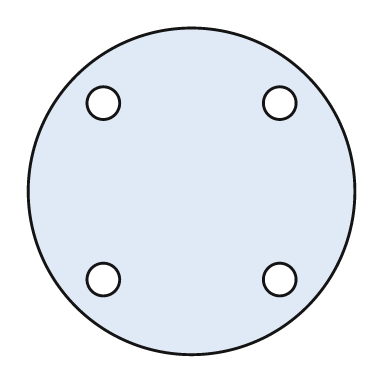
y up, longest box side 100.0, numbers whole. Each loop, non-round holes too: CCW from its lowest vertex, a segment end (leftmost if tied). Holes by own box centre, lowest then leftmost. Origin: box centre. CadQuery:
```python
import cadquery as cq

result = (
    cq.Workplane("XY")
    .moveTo(0.0, 0.0)
    .circle(50.0)
    .moveTo(-27.0, -27.0)
    .circle(5.0)
    .moveTo(27.0, -27.0)
    .circle(5.0)
    .moveTo(-27.0, 27.0)
    .circle(5.0)
    .moveTo(27.0, 27.0)
    .circle(5.0)
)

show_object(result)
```